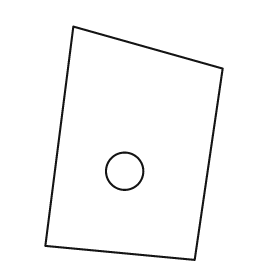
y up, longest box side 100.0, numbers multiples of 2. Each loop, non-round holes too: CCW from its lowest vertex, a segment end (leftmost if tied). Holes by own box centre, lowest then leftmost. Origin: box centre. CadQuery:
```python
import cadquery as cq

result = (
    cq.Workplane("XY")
    .moveTo(26.0, -50.0)
    .lineTo(38.0, 32.0)
    .lineTo(-26.0, 50.0)
    .lineTo(-38.0, -44.0)
    .close()
    .moveTo(-4.0, -12.0)
    .circle(8.0)
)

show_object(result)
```